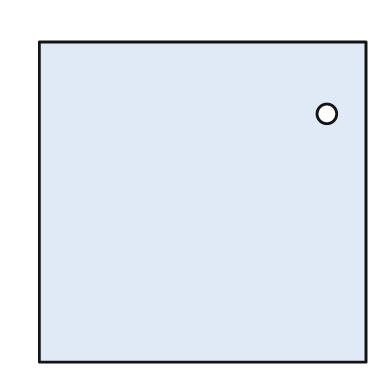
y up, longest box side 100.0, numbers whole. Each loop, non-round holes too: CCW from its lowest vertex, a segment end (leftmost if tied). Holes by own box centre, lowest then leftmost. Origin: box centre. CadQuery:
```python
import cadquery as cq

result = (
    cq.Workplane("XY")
    .moveTo(-50.0, -49.0)
    .lineTo(50.0, -49.0)
    .lineTo(50.0, 49.0)
    .lineTo(-50.0, 49.0)
    .close()
    .moveTo(38.0, 27.0)
    .circle(3.0)
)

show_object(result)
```